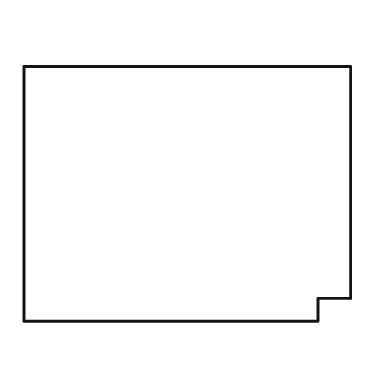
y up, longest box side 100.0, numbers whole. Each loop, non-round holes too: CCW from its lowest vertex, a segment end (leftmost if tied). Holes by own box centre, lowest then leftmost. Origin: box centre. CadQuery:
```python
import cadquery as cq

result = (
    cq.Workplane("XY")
    .moveTo(-50.0, -39.0)
    .lineTo(40.0, -39.0)
    .lineTo(40.0, -32.0)
    .lineTo(50.0, -32.0)
    .lineTo(50.0, 39.0)
    .lineTo(-50.0, 39.0)
    .close()
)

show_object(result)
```